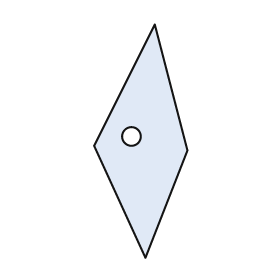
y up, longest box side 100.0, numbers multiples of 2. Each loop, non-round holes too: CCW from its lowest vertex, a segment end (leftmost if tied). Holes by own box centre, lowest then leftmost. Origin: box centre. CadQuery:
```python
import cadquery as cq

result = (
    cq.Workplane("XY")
    .moveTo(2.0, -50.0)
    .lineTo(20.0, -4.0)
    .lineTo(6.0, 50.0)
    .lineTo(-20.0, -2.0)
    .close()
    .moveTo(-4.0, 2.0)
    .circle(4.0)
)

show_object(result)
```